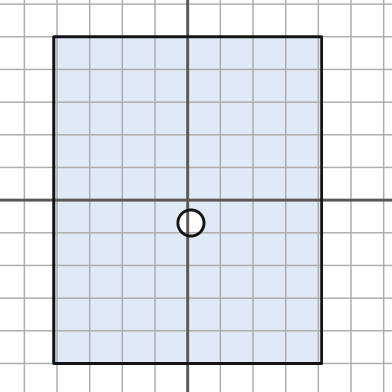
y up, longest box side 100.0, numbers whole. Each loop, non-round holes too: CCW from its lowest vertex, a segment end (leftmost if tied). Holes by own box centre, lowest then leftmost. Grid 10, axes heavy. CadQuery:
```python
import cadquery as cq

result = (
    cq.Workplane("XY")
    .moveTo(-41.0, -50.0)
    .lineTo(41.0, -50.0)
    .lineTo(41.0, 50.0)
    .lineTo(-41.0, 50.0)
    .close()
    .moveTo(1.0, -7.0)
    .circle(4.0)
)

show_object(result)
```